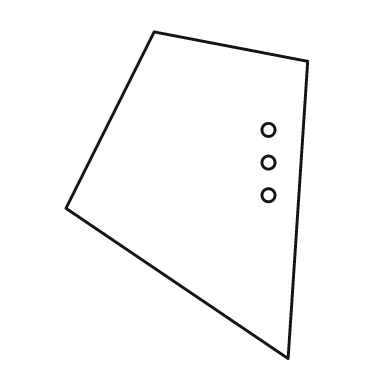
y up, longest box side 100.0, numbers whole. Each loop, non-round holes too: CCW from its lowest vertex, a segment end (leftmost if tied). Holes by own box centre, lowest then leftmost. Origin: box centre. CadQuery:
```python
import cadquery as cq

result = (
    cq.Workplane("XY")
    .moveTo(31.0, -50.0)
    .lineTo(37.0, 41.0)
    .lineTo(-10.0, 50.0)
    .lineTo(-37.0, -4.0)
    .close()
    .moveTo(25.0, 0.0)
    .circle(2.0)
    .moveTo(25.0, 10.0)
    .circle(2.0)
    .moveTo(25.0, 20.0)
    .circle(2.0)
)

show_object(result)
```